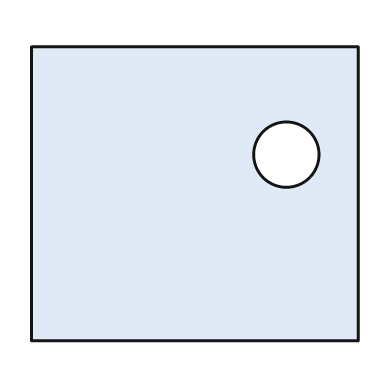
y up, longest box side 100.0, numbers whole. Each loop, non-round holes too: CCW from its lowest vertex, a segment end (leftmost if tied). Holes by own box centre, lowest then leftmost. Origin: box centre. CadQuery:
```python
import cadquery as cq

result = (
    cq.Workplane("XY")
    .moveTo(-50.0, -45.0)
    .lineTo(50.0, -45.0)
    .lineTo(50.0, 45.0)
    .lineTo(-50.0, 45.0)
    .close()
    .moveTo(28.0, 12.0)
    .circle(10.0)
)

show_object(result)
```